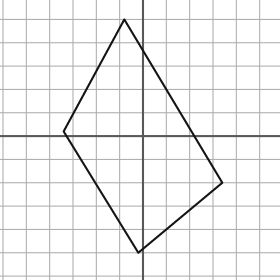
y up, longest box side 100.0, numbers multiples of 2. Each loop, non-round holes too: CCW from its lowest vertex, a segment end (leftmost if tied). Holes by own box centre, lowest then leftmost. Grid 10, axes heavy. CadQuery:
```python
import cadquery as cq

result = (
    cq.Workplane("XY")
    .moveTo(-2.0, -50.0)
    .lineTo(34.0, -20.0)
    .lineTo(-8.0, 50.0)
    .lineTo(-34.0, 2.0)
    .close()
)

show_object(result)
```